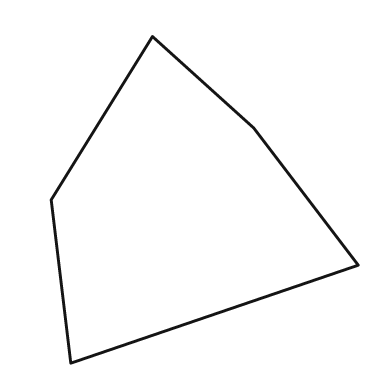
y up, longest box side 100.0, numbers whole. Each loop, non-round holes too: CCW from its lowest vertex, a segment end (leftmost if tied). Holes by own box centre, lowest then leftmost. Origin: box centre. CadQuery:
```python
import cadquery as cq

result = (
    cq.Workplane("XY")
    .moveTo(-41.0, -50.0)
    .lineTo(47.0, -20.0)
    .lineTo(15.0, 22.0)
    .lineTo(-16.0, 50.0)
    .lineTo(-47.0, 0.0)
    .close()
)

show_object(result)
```